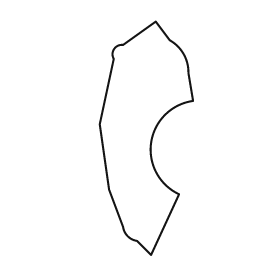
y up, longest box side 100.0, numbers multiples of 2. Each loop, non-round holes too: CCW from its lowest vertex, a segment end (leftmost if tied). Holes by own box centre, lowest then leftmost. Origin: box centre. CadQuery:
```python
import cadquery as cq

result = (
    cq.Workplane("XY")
    .moveTo(2.0, -50.0)
    .lineTo(14.0, -24.0)
    .threePointArc((2.0, -2.0), (20.0, 16.0))
    .lineTo(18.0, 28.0)
    .threePointArc((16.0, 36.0), (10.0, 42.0))
    .lineTo(4.0, 50.0)
    .lineTo(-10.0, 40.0)
    .threePointArc((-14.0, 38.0), (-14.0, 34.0))
    .lineTo(-20.0, 6.0)
    .lineTo(-16.0, -22.0)
    .lineTo(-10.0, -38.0)
    .threePointArc((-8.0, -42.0), (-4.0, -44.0))
    .close()
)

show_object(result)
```